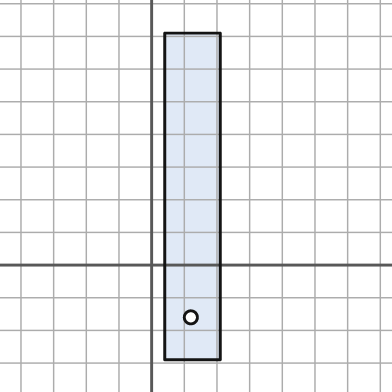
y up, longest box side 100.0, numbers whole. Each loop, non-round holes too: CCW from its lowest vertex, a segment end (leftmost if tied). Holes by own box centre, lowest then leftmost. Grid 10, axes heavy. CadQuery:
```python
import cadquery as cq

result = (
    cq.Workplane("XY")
    .moveTo(4.0, -29.0)
    .lineTo(21.0, -29.0)
    .lineTo(21.0, 71.0)
    .lineTo(4.0, 71.0)
    .close()
    .moveTo(12.0, -16.0)
    .circle(2.0)
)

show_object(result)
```